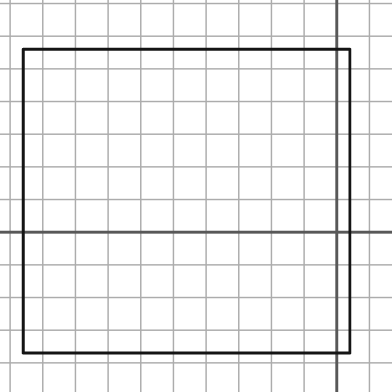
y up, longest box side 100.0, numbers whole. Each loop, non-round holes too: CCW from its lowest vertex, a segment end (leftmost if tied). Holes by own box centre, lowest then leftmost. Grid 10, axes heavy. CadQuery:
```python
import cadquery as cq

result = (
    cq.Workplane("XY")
    .moveTo(-96.0, -37.0)
    .lineTo(4.0, -37.0)
    .lineTo(4.0, 56.0)
    .lineTo(-96.0, 56.0)
    .close()
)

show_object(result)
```